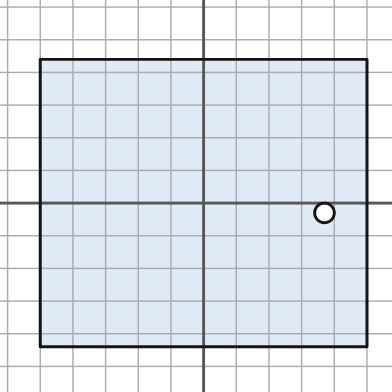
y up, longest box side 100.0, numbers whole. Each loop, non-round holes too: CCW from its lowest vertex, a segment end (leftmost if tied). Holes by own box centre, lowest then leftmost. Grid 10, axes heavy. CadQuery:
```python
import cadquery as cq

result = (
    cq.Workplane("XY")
    .moveTo(-50.0, -44.0)
    .lineTo(50.0, -44.0)
    .lineTo(50.0, 44.0)
    .lineTo(-50.0, 44.0)
    .close()
    .moveTo(37.0, -3.0)
    .circle(3.0)
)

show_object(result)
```